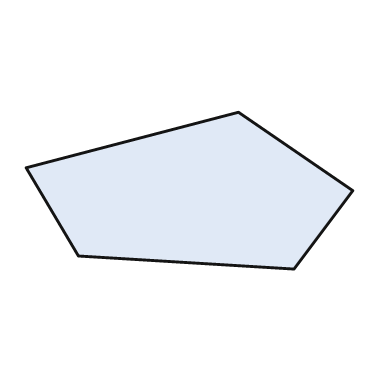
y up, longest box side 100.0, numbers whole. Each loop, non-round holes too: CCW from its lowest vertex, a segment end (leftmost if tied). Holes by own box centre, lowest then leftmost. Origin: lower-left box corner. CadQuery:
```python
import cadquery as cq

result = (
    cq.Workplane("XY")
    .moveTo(82.0, 0.0)
    .lineTo(100.0, 24.0)
    .lineTo(65.0, 48.0)
    .lineTo(0.0, 31.0)
    .lineTo(16.0, 4.0)
    .close()
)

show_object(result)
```